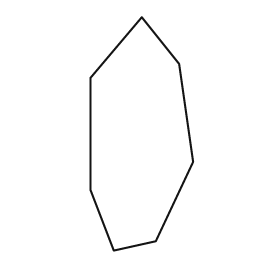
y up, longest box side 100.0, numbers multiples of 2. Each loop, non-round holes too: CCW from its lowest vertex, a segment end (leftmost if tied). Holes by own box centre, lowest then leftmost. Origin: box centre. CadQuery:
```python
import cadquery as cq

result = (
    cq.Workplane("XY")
    .moveTo(-12.0, -50.0)
    .lineTo(6.0, -46.0)
    .lineTo(22.0, -12.0)
    .lineTo(16.0, 30.0)
    .lineTo(0.0, 50.0)
    .lineTo(-22.0, 24.0)
    .lineTo(-22.0, -24.0)
    .close()
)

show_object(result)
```